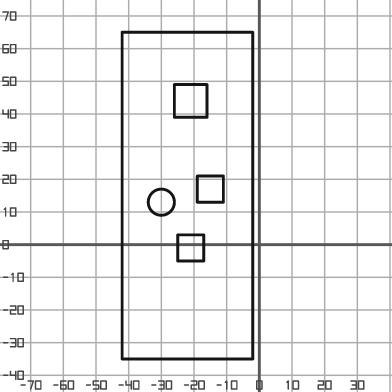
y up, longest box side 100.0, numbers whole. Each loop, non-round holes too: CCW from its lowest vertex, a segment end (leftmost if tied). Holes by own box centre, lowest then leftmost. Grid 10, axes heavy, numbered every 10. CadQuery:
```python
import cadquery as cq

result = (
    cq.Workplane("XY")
    .moveTo(-42.0, -35.0)
    .lineTo(-2.0, -35.0)
    .lineTo(-2.0, 65.0)
    .lineTo(-42.0, 65.0)
    .close()
    .moveTo(-25.0, -5.0)
    .lineTo(-17.0, -5.0)
    .lineTo(-17.0, 3.0)
    .lineTo(-25.0, 3.0)
    .close()
    .moveTo(-30.0, 13.0)
    .circle(4.0)
    .moveTo(-19.0, 13.0)
    .lineTo(-11.0, 13.0)
    .lineTo(-11.0, 21.0)
    .lineTo(-19.0, 21.0)
    .close()
    .moveTo(-26.0, 39.0)
    .lineTo(-16.0, 39.0)
    .lineTo(-16.0, 49.0)
    .lineTo(-26.0, 49.0)
    .close()
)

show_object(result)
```